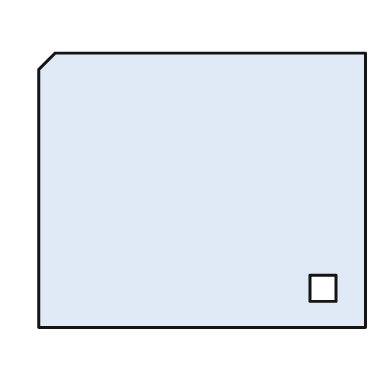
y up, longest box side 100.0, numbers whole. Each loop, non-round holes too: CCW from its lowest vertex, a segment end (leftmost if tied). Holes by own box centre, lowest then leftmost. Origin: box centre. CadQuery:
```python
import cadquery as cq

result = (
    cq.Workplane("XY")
    .moveTo(-50.0, -42.0)
    .lineTo(50.0, -42.0)
    .lineTo(50.0, 42.0)
    .lineTo(-45.0, 42.0)
    .lineTo(-50.0, 37.0)
    .close()
    .moveTo(33.0, -34.0)
    .lineTo(41.0, -34.0)
    .lineTo(41.0, -26.0)
    .lineTo(33.0, -26.0)
    .close()
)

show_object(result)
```